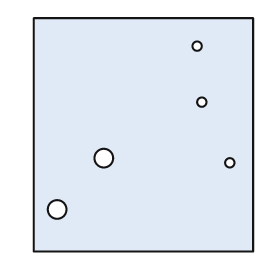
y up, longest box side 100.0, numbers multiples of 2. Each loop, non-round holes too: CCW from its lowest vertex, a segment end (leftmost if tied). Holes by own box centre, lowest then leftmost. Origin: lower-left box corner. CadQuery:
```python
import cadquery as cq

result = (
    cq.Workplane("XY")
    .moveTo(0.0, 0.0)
    .lineTo(94.0, 0.0)
    .lineTo(94.0, 100.0)
    .lineTo(0.0, 100.0)
    .close()
    .moveTo(10.0, 18.0)
    .circle(4.0)
    .moveTo(84.0, 38.0)
    .circle(2.0)
    .moveTo(30.0, 40.0)
    .circle(4.0)
    .moveTo(72.0, 64.0)
    .circle(2.0)
    .moveTo(70.0, 88.0)
    .circle(2.0)
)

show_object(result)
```